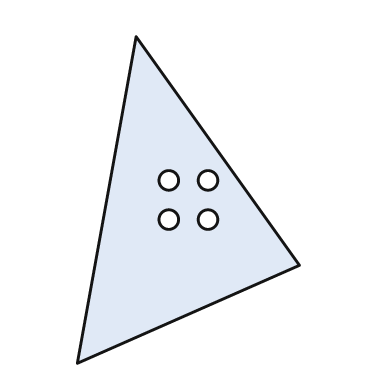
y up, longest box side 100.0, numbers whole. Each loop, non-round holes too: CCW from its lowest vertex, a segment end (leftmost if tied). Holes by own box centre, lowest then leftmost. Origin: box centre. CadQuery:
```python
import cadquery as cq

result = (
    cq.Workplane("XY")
    .moveTo(-34.0, -50.0)
    .lineTo(34.0, -20.0)
    .lineTo(-16.0, 50.0)
    .close()
    .moveTo(-6.0, -6.0)
    .circle(3.0)
    .moveTo(6.0, -6.0)
    .circle(3.0)
    .moveTo(-6.0, 6.0)
    .circle(3.0)
    .moveTo(6.0, 6.0)
    .circle(3.0)
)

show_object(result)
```